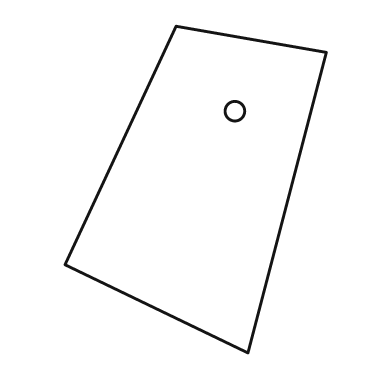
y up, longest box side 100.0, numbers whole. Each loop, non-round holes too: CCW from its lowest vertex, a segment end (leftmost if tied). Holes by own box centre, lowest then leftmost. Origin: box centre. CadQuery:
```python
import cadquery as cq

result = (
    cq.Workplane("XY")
    .moveTo(16.0, -50.0)
    .lineTo(40.0, 42.0)
    .lineTo(-6.0, 50.0)
    .lineTo(-40.0, -23.0)
    .close()
    .moveTo(12.0, 24.0)
    .circle(3.0)
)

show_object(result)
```